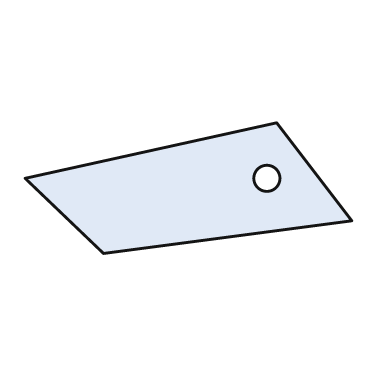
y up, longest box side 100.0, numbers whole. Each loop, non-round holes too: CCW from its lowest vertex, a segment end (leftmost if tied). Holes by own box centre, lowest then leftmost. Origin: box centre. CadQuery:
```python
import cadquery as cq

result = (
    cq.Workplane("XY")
    .moveTo(-26.0, -20.0)
    .lineTo(50.0, -10.0)
    .lineTo(27.0, 20.0)
    .lineTo(-50.0, 3.0)
    .close()
    .moveTo(24.0, 3.0)
    .circle(4.0)
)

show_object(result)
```